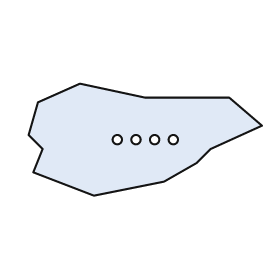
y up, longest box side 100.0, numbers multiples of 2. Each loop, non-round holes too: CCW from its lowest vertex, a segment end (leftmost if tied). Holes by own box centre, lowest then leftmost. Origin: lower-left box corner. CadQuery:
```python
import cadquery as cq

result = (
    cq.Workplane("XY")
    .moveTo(28.0, 0.0)
    .lineTo(58.0, 6.0)
    .lineTo(72.0, 14.0)
    .lineTo(78.0, 20.0)
    .lineTo(100.0, 30.0)
    .lineTo(86.0, 42.0)
    .lineTo(50.0, 42.0)
    .lineTo(22.0, 48.0)
    .lineTo(4.0, 40.0)
    .lineTo(0.0, 26.0)
    .lineTo(6.0, 20.0)
    .lineTo(2.0, 10.0)
    .close()
    .moveTo(38.0, 24.0)
    .circle(2.0)
    .moveTo(46.0, 24.0)
    .circle(2.0)
    .moveTo(54.0, 24.0)
    .circle(2.0)
    .moveTo(62.0, 24.0)
    .circle(2.0)
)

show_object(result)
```